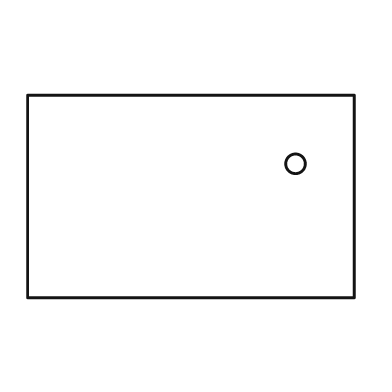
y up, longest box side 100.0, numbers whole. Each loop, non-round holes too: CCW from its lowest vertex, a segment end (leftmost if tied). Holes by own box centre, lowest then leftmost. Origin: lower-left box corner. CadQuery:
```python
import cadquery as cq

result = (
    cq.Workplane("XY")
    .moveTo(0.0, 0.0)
    .lineTo(100.0, 0.0)
    .lineTo(100.0, 62.0)
    .lineTo(0.0, 62.0)
    .close()
    .moveTo(82.0, 41.0)
    .circle(3.0)
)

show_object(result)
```